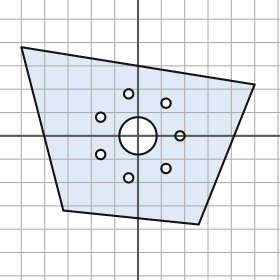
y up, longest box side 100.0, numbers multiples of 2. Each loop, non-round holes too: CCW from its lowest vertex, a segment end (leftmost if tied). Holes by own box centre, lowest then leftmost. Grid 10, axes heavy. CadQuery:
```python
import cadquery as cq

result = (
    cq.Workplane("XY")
    .moveTo(26.0, -38.0)
    .lineTo(50.0, 22.0)
    .lineTo(-50.0, 38.0)
    .lineTo(-32.0, -32.0)
    .close()
    .moveTo(-4.0, -18.0)
    .circle(2.0)
    .moveTo(12.0, -14.0)
    .circle(2.0)
    .moveTo(-16.0, -8.0)
    .circle(2.0)
    .moveTo(0.0, 0.0)
    .circle(8.0)
    .moveTo(18.0, 0.0)
    .circle(2.0)
    .moveTo(-16.0, 8.0)
    .circle(2.0)
    .moveTo(12.0, 14.0)
    .circle(2.0)
    .moveTo(-4.0, 18.0)
    .circle(2.0)
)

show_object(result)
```